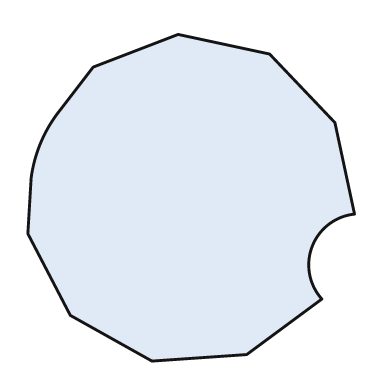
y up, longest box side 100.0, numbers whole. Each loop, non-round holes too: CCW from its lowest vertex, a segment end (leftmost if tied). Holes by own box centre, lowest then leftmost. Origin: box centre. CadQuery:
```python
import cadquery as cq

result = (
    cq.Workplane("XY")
    .moveTo(-12.0, -50.0)
    .lineTo(17.0, -48.0)
    .lineTo(40.0, -31.0)
    .threePointArc((37.0, -15.0), (50.0, -5.0))
    .lineTo(44.0, 23.0)
    .lineTo(24.0, 44.0)
    .lineTo(-4.0, 50.0)
    .lineTo(-30.0, 40.0)
    .lineTo(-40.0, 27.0)
    .threePointArc((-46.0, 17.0), (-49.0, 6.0))
    .lineTo(-50.0, -11.0)
    .lineTo(-37.0, -36.0)
    .close()
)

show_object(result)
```